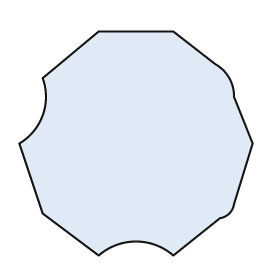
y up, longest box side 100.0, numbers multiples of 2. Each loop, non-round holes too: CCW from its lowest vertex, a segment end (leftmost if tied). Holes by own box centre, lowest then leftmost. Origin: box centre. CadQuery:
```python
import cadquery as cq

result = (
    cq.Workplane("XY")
    .moveTo(-16.0, -48.0)
    .threePointArc((0.0, -42.0), (16.0, -48.0))
    .lineTo(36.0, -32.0)
    .threePointArc((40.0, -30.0), (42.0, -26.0))
    .lineTo(50.0, 0.0)
    .lineTo(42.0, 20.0)
    .threePointArc((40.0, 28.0), (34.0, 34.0))
    .lineTo(16.0, 48.0)
    .lineTo(-16.0, 48.0)
    .lineTo(-40.0, 28.0)
    .threePointArc((-40.0, 12.0), (-50.0, 0.0))
    .lineTo(-40.0, -30.0)
    .close()
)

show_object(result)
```